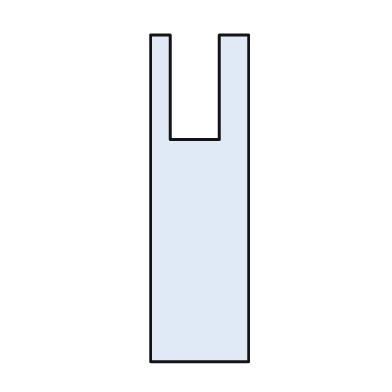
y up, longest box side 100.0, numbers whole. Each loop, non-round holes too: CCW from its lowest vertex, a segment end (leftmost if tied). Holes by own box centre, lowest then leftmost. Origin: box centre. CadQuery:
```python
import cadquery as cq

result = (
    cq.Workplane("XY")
    .moveTo(-15.0, -50.0)
    .lineTo(15.0, -50.0)
    .lineTo(15.0, 50.0)
    .lineTo(6.0, 50.0)
    .lineTo(6.0, 18.0)
    .lineTo(-9.0, 18.0)
    .lineTo(-9.0, 50.0)
    .lineTo(-15.0, 50.0)
    .close()
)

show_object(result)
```